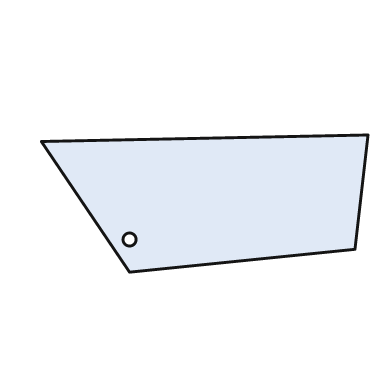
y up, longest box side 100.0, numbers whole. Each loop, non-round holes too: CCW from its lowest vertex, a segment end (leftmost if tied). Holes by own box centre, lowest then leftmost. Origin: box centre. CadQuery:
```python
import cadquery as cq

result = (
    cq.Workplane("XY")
    .moveTo(-23.0, -21.0)
    .lineTo(46.0, -14.0)
    .lineTo(50.0, 21.0)
    .lineTo(-50.0, 19.0)
    .close()
    .moveTo(-23.0, -11.0)
    .circle(2.0)
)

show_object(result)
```